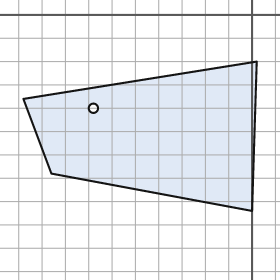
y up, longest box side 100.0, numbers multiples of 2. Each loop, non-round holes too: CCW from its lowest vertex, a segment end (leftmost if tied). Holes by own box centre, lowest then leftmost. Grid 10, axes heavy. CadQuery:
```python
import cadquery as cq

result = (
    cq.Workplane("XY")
    .moveTo(0.0, -84.0)
    .lineTo(2.0, -20.0)
    .lineTo(-98.0, -36.0)
    .lineTo(-86.0, -68.0)
    .close()
    .moveTo(-68.0, -40.0)
    .circle(2.0)
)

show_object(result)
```